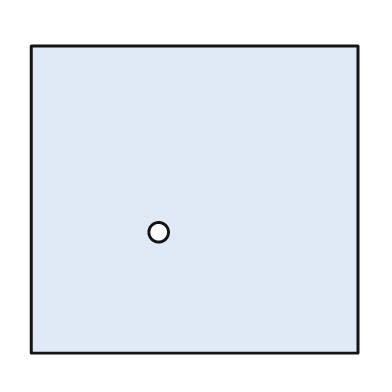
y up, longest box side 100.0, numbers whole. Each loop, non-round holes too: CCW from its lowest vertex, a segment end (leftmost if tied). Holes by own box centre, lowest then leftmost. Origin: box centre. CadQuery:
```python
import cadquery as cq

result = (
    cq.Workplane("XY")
    .moveTo(-50.0, -47.0)
    .lineTo(50.0, -47.0)
    .lineTo(50.0, 47.0)
    .lineTo(-50.0, 47.0)
    .close()
    .moveTo(-11.0, -10.0)
    .circle(3.0)
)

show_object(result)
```